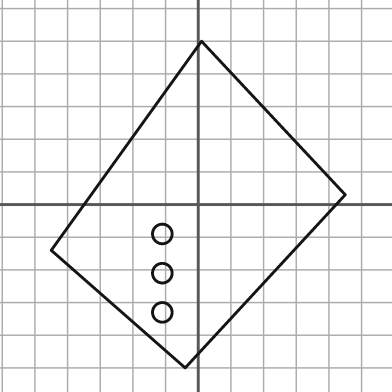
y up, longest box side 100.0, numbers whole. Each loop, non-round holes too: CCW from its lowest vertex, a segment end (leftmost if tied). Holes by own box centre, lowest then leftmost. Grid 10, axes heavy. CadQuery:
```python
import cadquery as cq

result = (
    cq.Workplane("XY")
    .moveTo(-4.0, -50.0)
    .lineTo(45.0, 3.0)
    .lineTo(1.0, 50.0)
    .lineTo(-45.0, -14.0)
    .close()
    .moveTo(-11.0, -33.0)
    .circle(3.0)
    .moveTo(-11.0, -21.0)
    .circle(3.0)
    .moveTo(-11.0, -9.0)
    .circle(3.0)
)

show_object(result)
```